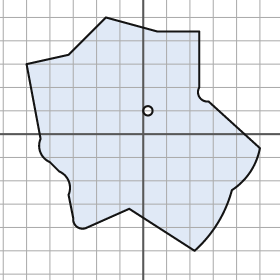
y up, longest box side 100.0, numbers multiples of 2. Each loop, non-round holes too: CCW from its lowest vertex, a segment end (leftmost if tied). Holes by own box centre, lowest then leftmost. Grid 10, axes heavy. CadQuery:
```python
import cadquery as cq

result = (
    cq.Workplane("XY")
    .moveTo(22.0, -50.0)
    .threePointArc((32.0, -38.0), (38.0, -24.0))
    .threePointArc((46.0, -16.0), (50.0, -6.0))
    .lineTo(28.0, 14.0)
    .threePointArc((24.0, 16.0), (24.0, 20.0))
    .lineTo(24.0, 44.0)
    .lineTo(6.0, 44.0)
    .lineTo(-16.0, 50.0)
    .lineTo(-32.0, 34.0)
    .lineTo(-50.0, 30.0)
    .lineTo(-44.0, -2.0)
    .threePointArc((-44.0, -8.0), (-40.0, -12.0))
    .lineTo(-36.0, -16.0)
    .threePointArc((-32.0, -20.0), (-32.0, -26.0))
    .lineTo(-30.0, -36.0)
    .threePointArc((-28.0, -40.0), (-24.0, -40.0))
    .lineTo(-6.0, -32.0)
    .close()
    .moveTo(2.0, 10.0)
    .circle(2.0)
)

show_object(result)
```